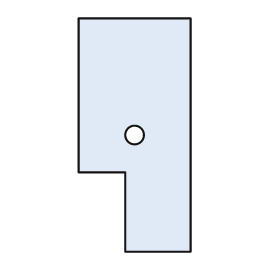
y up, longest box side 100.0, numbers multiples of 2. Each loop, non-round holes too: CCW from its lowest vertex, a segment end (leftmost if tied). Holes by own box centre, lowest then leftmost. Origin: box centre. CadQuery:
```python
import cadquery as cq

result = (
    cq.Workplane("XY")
    .moveTo(-4.0, -50.0)
    .lineTo(24.0, -50.0)
    .lineTo(24.0, 50.0)
    .lineTo(-24.0, 50.0)
    .lineTo(-24.0, -16.0)
    .lineTo(-4.0, -16.0)
    .close()
    .moveTo(0.0, 0.0)
    .circle(4.0)
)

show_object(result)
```